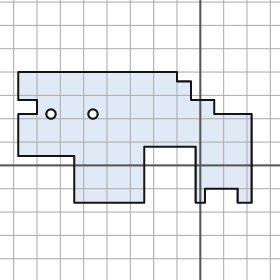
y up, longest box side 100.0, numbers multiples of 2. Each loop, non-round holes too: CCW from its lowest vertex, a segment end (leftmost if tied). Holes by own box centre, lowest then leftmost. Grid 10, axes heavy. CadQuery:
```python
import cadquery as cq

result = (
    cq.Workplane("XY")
    .moveTo(-54.0, -16.0)
    .lineTo(-24.0, -16.0)
    .lineTo(-24.0, 8.0)
    .lineTo(-2.0, 8.0)
    .lineTo(-2.0, -16.0)
    .lineTo(2.0, -16.0)
    .lineTo(2.0, -10.0)
    .lineTo(16.0, -10.0)
    .lineTo(16.0, -16.0)
    .lineTo(22.0, -16.0)
    .lineTo(22.0, 22.0)
    .lineTo(6.0, 22.0)
    .lineTo(6.0, 28.0)
    .lineTo(-4.0, 28.0)
    .lineTo(-4.0, 36.0)
    .lineTo(-10.0, 36.0)
    .lineTo(-10.0, 40.0)
    .lineTo(-78.0, 40.0)
    .lineTo(-78.0, 28.0)
    .lineTo(-70.0, 28.0)
    .lineTo(-70.0, 22.0)
    .lineTo(-78.0, 22.0)
    .lineTo(-78.0, 4.0)
    .lineTo(-54.0, 4.0)
    .close()
    .moveTo(-64.0, 22.0)
    .circle(2.0)
    .moveTo(-46.0, 22.0)
    .circle(2.0)
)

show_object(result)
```